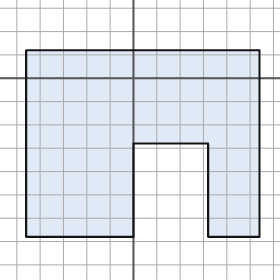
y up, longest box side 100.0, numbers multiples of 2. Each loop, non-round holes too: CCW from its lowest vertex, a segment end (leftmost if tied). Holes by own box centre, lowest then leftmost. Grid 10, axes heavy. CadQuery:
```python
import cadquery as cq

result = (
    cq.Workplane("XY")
    .moveTo(-46.0, -68.0)
    .lineTo(0.0, -68.0)
    .lineTo(0.0, -28.0)
    .lineTo(32.0, -28.0)
    .lineTo(32.0, -68.0)
    .lineTo(54.0, -68.0)
    .lineTo(54.0, 12.0)
    .lineTo(-46.0, 12.0)
    .close()
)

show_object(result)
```